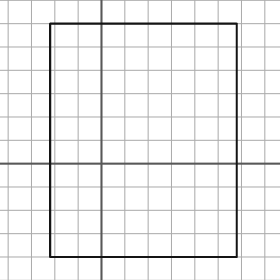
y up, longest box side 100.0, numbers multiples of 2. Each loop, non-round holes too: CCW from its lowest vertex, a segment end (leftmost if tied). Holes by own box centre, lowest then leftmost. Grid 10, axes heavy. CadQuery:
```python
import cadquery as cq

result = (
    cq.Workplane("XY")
    .moveTo(-22.0, -40.0)
    .lineTo(58.0, -40.0)
    .lineTo(58.0, 60.0)
    .lineTo(-22.0, 60.0)
    .close()
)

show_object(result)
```